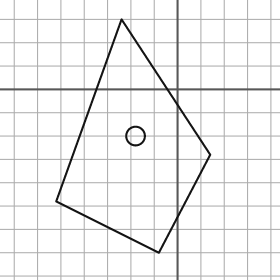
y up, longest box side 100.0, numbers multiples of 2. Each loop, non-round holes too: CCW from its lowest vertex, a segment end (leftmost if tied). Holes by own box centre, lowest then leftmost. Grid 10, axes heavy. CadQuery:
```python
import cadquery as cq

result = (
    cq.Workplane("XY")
    .moveTo(-8.0, -70.0)
    .lineTo(14.0, -28.0)
    .lineTo(-24.0, 30.0)
    .lineTo(-52.0, -48.0)
    .close()
    .moveTo(-18.0, -20.0)
    .circle(4.0)
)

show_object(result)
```